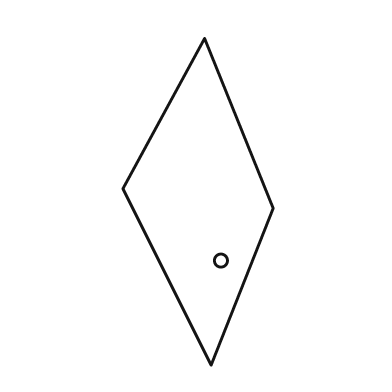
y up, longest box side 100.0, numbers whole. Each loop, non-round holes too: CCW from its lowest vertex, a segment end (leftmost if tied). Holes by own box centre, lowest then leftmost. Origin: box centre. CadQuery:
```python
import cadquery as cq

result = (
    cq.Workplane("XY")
    .moveTo(4.0, -50.0)
    .lineTo(23.0, -2.0)
    .lineTo(2.0, 50.0)
    .lineTo(-23.0, 4.0)
    .close()
    .moveTo(7.0, -18.0)
    .circle(2.0)
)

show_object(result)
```